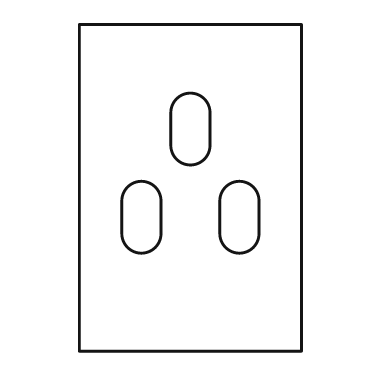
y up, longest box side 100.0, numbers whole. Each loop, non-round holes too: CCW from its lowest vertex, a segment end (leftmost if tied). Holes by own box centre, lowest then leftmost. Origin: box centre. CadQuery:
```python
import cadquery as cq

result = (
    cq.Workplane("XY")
    .moveTo(-34.0, -50.0)
    .lineTo(34.0, -50.0)
    .lineTo(34.0, 50.0)
    .lineTo(-34.0, 50.0)
    .close()
    .moveTo(-21.0, -14.0)
    .threePointArc((-15.0, -20.0), (-9.0, -14.0))
    .lineTo(-9.0, -4.0)
    .threePointArc((-15.0, 2.0), (-21.0, -4.0))
    .close()
    .moveTo(9.0, -14.0)
    .threePointArc((15.0, -20.0), (21.0, -14.0))
    .lineTo(21.0, -4.0)
    .threePointArc((15.0, 2.0), (9.0, -4.0))
    .close()
    .moveTo(-6.0, 13.0)
    .threePointArc((0.0, 7.0), (6.0, 13.0))
    .lineTo(6.0, 23.0)
    .threePointArc((0.0, 29.0), (-6.0, 23.0))
    .close()
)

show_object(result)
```